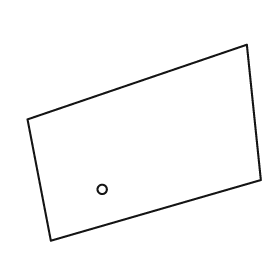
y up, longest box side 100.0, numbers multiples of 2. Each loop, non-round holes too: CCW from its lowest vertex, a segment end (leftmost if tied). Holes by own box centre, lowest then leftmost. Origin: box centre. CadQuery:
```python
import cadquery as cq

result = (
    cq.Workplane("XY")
    .moveTo(-40.0, -42.0)
    .lineTo(50.0, -16.0)
    .lineTo(44.0, 42.0)
    .lineTo(-50.0, 10.0)
    .close()
    .moveTo(-18.0, -20.0)
    .circle(2.0)
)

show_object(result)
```